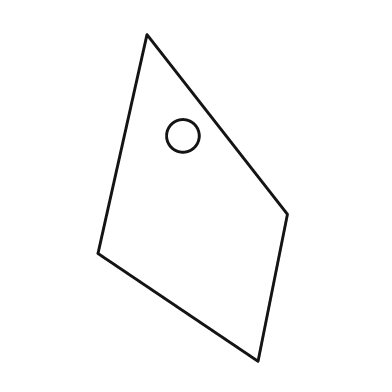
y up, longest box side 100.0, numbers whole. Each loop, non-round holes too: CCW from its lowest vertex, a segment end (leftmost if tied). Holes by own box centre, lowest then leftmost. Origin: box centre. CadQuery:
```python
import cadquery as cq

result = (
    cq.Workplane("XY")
    .moveTo(20.0, -50.0)
    .lineTo(29.0, -5.0)
    .lineTo(-14.0, 50.0)
    .lineTo(-29.0, -17.0)
    .close()
    .moveTo(-3.0, 19.0)
    .circle(5.0)
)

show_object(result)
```